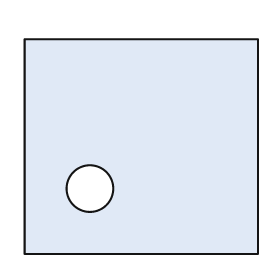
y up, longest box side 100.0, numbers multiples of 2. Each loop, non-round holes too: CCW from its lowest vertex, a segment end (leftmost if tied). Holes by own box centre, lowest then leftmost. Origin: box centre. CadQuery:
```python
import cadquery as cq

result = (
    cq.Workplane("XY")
    .moveTo(-50.0, -46.0)
    .lineTo(50.0, -46.0)
    .lineTo(50.0, 46.0)
    .lineTo(-50.0, 46.0)
    .close()
    .moveTo(-22.0, -18.0)
    .circle(10.0)
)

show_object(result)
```